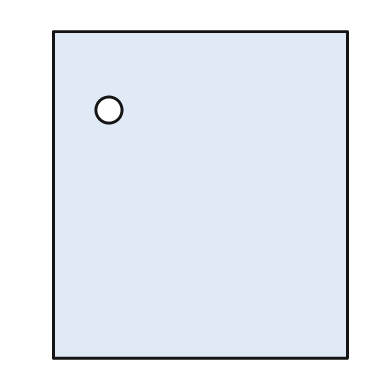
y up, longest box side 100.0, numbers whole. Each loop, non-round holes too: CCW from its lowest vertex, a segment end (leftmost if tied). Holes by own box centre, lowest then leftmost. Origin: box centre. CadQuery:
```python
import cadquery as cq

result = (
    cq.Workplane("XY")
    .moveTo(-45.0, -50.0)
    .lineTo(45.0, -50.0)
    .lineTo(45.0, 50.0)
    .lineTo(-45.0, 50.0)
    .close()
    .moveTo(-28.0, 26.0)
    .circle(4.0)
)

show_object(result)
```